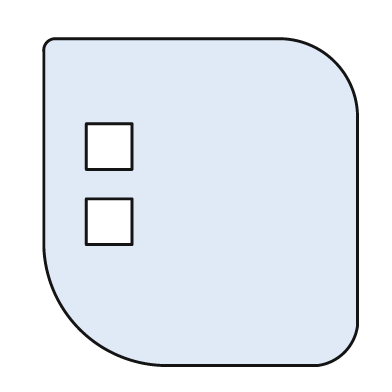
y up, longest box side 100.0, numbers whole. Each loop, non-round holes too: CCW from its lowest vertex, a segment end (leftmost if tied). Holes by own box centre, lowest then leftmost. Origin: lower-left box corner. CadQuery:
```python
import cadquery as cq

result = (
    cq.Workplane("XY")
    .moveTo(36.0, 0.0)
    .lineTo(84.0, 0.0)
    .threePointArc((92.0, 4.0), (96.0, 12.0))
    .lineTo(96.0, 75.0)
    .threePointArc((89.0, 93.0), (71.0, 100.0))
    .lineTo(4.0, 100.0)
    .threePointArc((1.0, 99.0), (0.0, 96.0))
    .lineTo(0.0, 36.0)
    .threePointArc((11.0, 11.0), (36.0, 0.0))
    .close()
    .moveTo(13.0, 37.0)
    .lineTo(27.0, 37.0)
    .lineTo(27.0, 51.0)
    .lineTo(13.0, 51.0)
    .close()
    .moveTo(13.0, 60.0)
    .lineTo(27.0, 60.0)
    .lineTo(27.0, 74.0)
    .lineTo(13.0, 74.0)
    .close()
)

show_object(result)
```